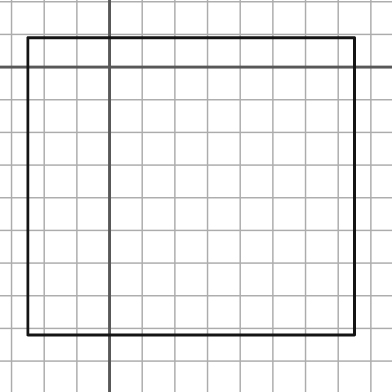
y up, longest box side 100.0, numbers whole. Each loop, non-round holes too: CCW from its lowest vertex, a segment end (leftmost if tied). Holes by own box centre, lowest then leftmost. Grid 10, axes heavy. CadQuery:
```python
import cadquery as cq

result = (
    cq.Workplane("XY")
    .moveTo(-25.0, -82.0)
    .lineTo(75.0, -82.0)
    .lineTo(75.0, 9.0)
    .lineTo(-25.0, 9.0)
    .close()
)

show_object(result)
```